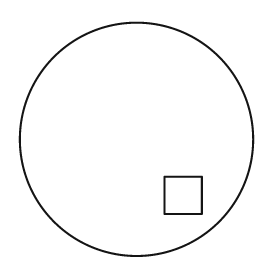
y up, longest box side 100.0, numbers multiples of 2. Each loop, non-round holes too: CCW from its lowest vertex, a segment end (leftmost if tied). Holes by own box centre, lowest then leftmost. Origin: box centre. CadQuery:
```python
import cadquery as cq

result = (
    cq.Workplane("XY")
    .moveTo(0.0, 0.0)
    .circle(50.0)
    .moveTo(12.0, -32.0)
    .lineTo(28.0, -32.0)
    .lineTo(28.0, -16.0)
    .lineTo(12.0, -16.0)
    .close()
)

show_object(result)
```